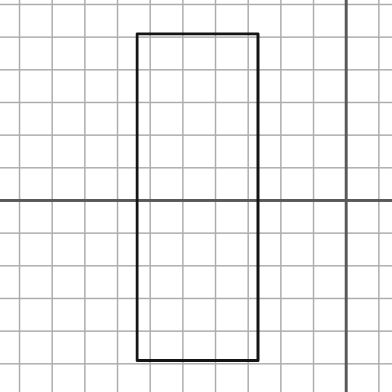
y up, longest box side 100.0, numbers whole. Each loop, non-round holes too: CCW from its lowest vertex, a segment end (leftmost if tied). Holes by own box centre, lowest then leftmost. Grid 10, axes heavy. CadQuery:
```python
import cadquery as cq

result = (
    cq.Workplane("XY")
    .moveTo(-64.0, -49.0)
    .lineTo(-27.0, -49.0)
    .lineTo(-27.0, 51.0)
    .lineTo(-64.0, 51.0)
    .close()
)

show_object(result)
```